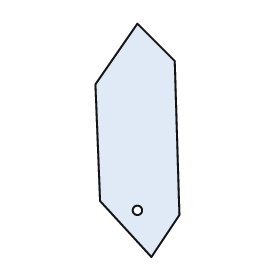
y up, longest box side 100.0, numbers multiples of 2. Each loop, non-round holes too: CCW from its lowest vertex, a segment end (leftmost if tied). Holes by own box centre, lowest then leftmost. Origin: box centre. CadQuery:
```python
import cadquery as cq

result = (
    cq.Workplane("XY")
    .moveTo(6.0, -50.0)
    .lineTo(18.0, -32.0)
    .lineTo(16.0, 34.0)
    .lineTo(0.0, 50.0)
    .lineTo(-18.0, 24.0)
    .lineTo(-16.0, -26.0)
    .close()
    .moveTo(0.0, -30.0)
    .circle(2.0)
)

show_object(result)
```